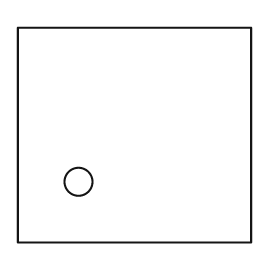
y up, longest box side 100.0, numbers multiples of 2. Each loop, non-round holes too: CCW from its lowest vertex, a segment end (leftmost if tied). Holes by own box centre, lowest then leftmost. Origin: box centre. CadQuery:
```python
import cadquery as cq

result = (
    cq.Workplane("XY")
    .moveTo(-50.0, -46.0)
    .lineTo(50.0, -46.0)
    .lineTo(50.0, 46.0)
    .lineTo(-50.0, 46.0)
    .close()
    .moveTo(-24.0, -20.0)
    .circle(6.0)
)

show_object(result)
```